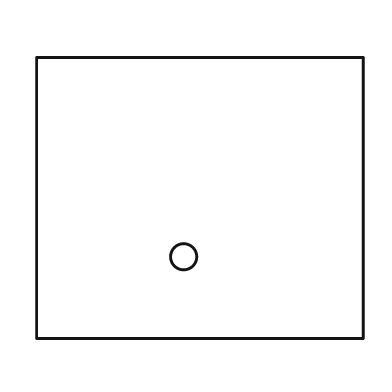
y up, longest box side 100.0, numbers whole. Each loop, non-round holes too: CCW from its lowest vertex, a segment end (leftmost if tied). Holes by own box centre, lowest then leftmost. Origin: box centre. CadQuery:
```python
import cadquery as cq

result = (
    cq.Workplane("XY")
    .moveTo(-50.0, -43.0)
    .lineTo(50.0, -43.0)
    .lineTo(50.0, 43.0)
    .lineTo(-50.0, 43.0)
    .close()
    .moveTo(-5.0, -18.0)
    .circle(4.0)
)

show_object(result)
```